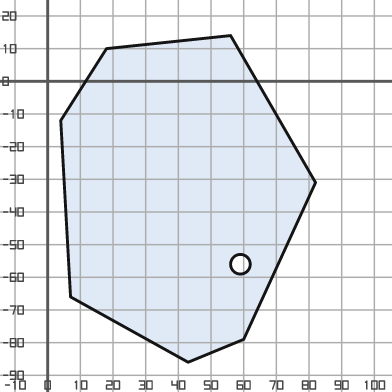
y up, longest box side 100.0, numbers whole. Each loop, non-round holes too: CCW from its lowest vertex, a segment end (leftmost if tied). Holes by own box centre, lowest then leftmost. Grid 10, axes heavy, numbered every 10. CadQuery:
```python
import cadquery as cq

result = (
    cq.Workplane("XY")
    .moveTo(43.0, -86.0)
    .lineTo(60.0, -79.0)
    .lineTo(82.0, -31.0)
    .lineTo(56.0, 14.0)
    .lineTo(18.0, 10.0)
    .lineTo(4.0, -12.0)
    .lineTo(7.0, -66.0)
    .close()
    .moveTo(59.0, -56.0)
    .circle(3.0)
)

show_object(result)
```